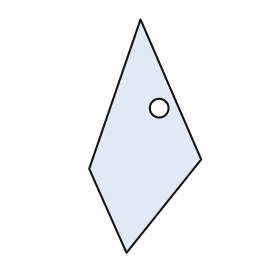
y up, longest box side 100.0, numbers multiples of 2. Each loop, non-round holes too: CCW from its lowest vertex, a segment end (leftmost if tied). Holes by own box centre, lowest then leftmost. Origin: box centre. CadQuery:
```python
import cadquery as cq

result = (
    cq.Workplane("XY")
    .moveTo(-8.0, -50.0)
    .lineTo(24.0, -10.0)
    .lineTo(-2.0, 50.0)
    .lineTo(-24.0, -14.0)
    .close()
    .moveTo(6.0, 12.0)
    .circle(4.0)
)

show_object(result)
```